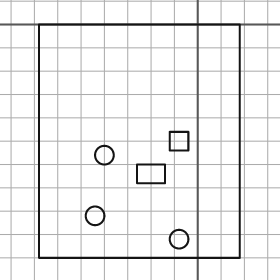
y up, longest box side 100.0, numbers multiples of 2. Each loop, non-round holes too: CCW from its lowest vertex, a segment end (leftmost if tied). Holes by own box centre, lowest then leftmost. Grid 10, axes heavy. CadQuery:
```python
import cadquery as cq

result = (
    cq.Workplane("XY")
    .moveTo(-68.0, -100.0)
    .lineTo(18.0, -100.0)
    .lineTo(18.0, 0.0)
    .lineTo(-68.0, 0.0)
    .close()
    .moveTo(-8.0, -92.0)
    .circle(4.0)
    .moveTo(-44.0, -82.0)
    .circle(4.0)
    .moveTo(-26.0, -68.0)
    .lineTo(-14.0, -68.0)
    .lineTo(-14.0, -60.0)
    .lineTo(-26.0, -60.0)
    .close()
    .moveTo(-40.0, -56.0)
    .circle(4.0)
    .moveTo(-12.0, -54.0)
    .lineTo(-4.0, -54.0)
    .lineTo(-4.0, -46.0)
    .lineTo(-12.0, -46.0)
    .close()
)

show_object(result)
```